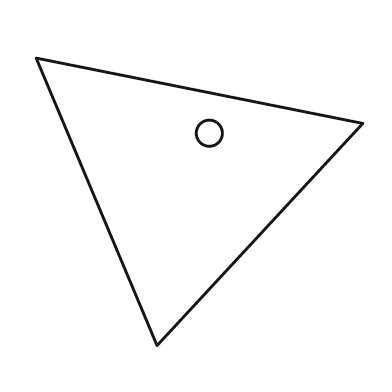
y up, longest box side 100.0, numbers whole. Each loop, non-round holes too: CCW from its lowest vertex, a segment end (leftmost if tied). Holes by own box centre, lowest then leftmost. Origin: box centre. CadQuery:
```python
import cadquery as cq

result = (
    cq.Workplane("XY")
    .moveTo(-13.0, -44.0)
    .lineTo(50.0, 24.0)
    .lineTo(-50.0, 44.0)
    .close()
    .moveTo(3.0, 21.0)
    .circle(4.0)
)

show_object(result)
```